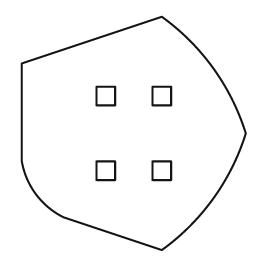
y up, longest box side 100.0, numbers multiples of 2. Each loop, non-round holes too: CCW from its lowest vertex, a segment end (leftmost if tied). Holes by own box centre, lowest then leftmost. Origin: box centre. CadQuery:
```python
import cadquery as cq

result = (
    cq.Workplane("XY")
    .moveTo(12.0, -50.0)
    .threePointArc((34.0, -28.0), (48.0, 0.0))
    .threePointArc((34.0, 28.0), (12.0, 50.0))
    .lineTo(-48.0, 30.0)
    .lineTo(-48.0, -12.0)
    .threePointArc((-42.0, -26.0), (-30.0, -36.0))
    .close()
    .moveTo(-16.0, -20.0)
    .lineTo(-8.0, -20.0)
    .lineTo(-8.0, -12.0)
    .lineTo(-16.0, -12.0)
    .close()
    .moveTo(8.0, -20.0)
    .lineTo(16.0, -20.0)
    .lineTo(16.0, -12.0)
    .lineTo(8.0, -12.0)
    .close()
    .moveTo(-16.0, 12.0)
    .lineTo(-8.0, 12.0)
    .lineTo(-8.0, 20.0)
    .lineTo(-16.0, 20.0)
    .close()
    .moveTo(8.0, 12.0)
    .lineTo(16.0, 12.0)
    .lineTo(16.0, 20.0)
    .lineTo(8.0, 20.0)
    .close()
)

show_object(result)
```